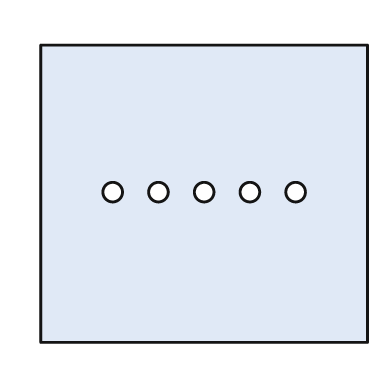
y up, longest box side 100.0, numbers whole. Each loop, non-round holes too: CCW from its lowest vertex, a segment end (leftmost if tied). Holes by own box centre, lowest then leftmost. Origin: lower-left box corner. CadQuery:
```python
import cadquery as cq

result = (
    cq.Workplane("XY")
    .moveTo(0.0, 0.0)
    .lineTo(100.0, 0.0)
    .lineTo(100.0, 91.0)
    .lineTo(0.0, 91.0)
    .close()
    .moveTo(22.0, 46.0)
    .circle(3.0)
    .moveTo(36.0, 46.0)
    .circle(3.0)
    .moveTo(50.0, 46.0)
    .circle(3.0)
    .moveTo(64.0, 46.0)
    .circle(3.0)
    .moveTo(78.0, 46.0)
    .circle(3.0)
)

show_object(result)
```